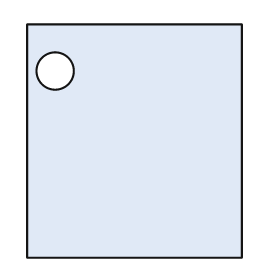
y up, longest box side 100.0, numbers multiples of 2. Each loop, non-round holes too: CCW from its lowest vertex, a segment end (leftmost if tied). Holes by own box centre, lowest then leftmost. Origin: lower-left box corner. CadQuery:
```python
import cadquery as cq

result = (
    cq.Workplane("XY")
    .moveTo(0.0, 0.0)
    .lineTo(92.0, 0.0)
    .lineTo(92.0, 100.0)
    .lineTo(0.0, 100.0)
    .close()
    .moveTo(12.0, 80.0)
    .circle(8.0)
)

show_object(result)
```